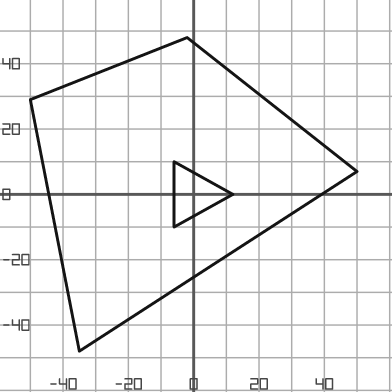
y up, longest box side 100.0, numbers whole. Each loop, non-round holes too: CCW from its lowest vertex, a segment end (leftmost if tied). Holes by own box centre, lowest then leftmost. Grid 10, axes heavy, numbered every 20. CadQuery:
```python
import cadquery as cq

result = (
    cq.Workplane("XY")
    .moveTo(-35.0, -48.0)
    .lineTo(50.0, 7.0)
    .lineTo(-2.0, 48.0)
    .lineTo(-50.0, 29.0)
    .close()
    .moveTo(-6.0, -10.0)
    .lineTo(12.0, 0.0)
    .lineTo(-6.0, 10.0)
    .close()
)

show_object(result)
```